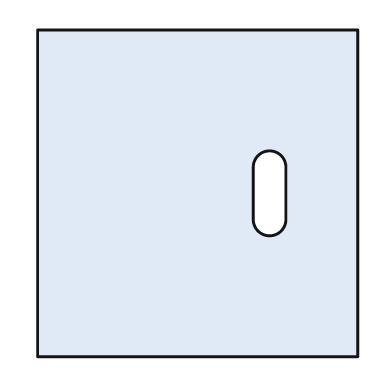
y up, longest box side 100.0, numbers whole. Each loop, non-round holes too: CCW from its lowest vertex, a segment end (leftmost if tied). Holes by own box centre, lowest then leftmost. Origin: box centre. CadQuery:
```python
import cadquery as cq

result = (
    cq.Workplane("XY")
    .moveTo(-49.0, -50.0)
    .lineTo(49.0, -50.0)
    .lineTo(49.0, 50.0)
    .lineTo(-49.0, 50.0)
    .close()
    .moveTo(17.0, -8.0)
    .threePointArc((22.0, -13.0), (27.0, -8.0))
    .lineTo(27.0, 8.0)
    .threePointArc((22.0, 13.0), (17.0, 8.0))
    .close()
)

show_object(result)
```